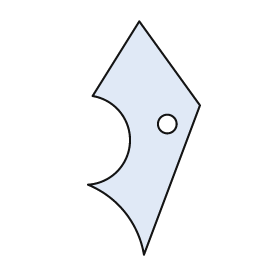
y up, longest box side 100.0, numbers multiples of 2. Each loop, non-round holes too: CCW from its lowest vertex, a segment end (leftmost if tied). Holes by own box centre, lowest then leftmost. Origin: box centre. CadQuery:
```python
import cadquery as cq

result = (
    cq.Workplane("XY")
    .moveTo(0.0, -50.0)
    .lineTo(24.0, 14.0)
    .lineTo(-2.0, 50.0)
    .lineTo(-22.0, 18.0)
    .threePointArc((-6.0, -2.0), (-24.0, -20.0))
    .threePointArc((-8.0, -32.0), (0.0, -50.0))
    .close()
    .moveTo(10.0, 6.0)
    .circle(4.0)
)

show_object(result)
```